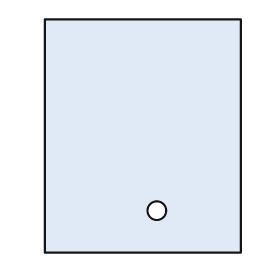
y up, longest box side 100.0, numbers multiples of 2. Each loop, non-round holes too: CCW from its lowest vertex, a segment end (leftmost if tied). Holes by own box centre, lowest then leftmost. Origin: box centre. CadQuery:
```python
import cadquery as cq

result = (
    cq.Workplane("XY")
    .moveTo(-42.0, -50.0)
    .lineTo(42.0, -50.0)
    .lineTo(42.0, 50.0)
    .lineTo(-42.0, 50.0)
    .close()
    .moveTo(6.0, -32.0)
    .circle(4.0)
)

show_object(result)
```